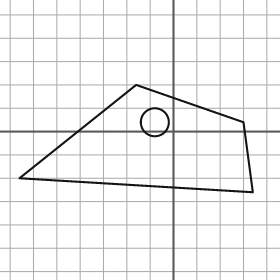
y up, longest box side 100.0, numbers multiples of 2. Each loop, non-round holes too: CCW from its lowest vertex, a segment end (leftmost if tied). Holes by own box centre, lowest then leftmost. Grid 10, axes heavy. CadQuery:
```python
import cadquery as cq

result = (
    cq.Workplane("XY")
    .moveTo(34.0, -26.0)
    .lineTo(30.0, 4.0)
    .lineTo(-16.0, 20.0)
    .lineTo(-66.0, -20.0)
    .close()
    .moveTo(-8.0, 4.0)
    .circle(6.0)
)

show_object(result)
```